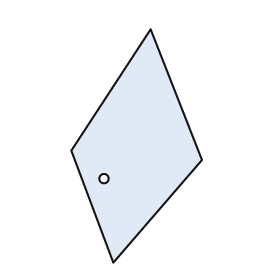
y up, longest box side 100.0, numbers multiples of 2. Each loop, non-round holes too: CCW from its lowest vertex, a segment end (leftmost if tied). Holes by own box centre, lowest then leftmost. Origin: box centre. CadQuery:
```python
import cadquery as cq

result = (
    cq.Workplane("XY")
    .moveTo(-10.0, -50.0)
    .lineTo(28.0, -6.0)
    .lineTo(6.0, 50.0)
    .lineTo(-28.0, -2.0)
    .close()
    .moveTo(-14.0, -14.0)
    .circle(2.0)
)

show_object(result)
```